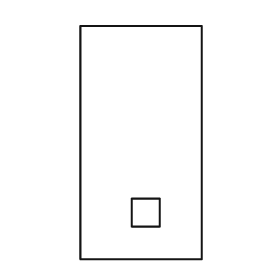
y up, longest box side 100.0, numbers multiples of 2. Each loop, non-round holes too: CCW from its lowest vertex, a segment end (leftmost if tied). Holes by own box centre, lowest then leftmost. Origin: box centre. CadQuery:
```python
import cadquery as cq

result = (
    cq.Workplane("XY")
    .moveTo(-26.0, -50.0)
    .lineTo(26.0, -50.0)
    .lineTo(26.0, 50.0)
    .lineTo(-26.0, 50.0)
    .close()
    .moveTo(-4.0, -36.0)
    .lineTo(8.0, -36.0)
    .lineTo(8.0, -24.0)
    .lineTo(-4.0, -24.0)
    .close()
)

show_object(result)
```